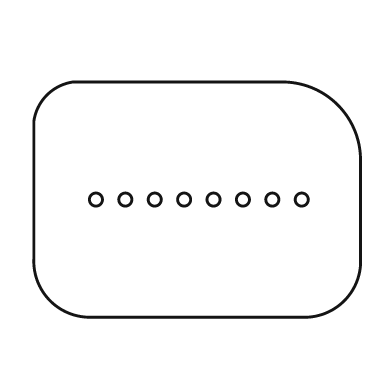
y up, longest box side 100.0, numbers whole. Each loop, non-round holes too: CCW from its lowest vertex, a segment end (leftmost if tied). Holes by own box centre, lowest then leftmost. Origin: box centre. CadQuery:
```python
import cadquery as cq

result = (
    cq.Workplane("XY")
    .moveTo(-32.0, -36.0)
    .lineTo(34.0, -36.0)
    .threePointArc((45.0, -31.0), (50.0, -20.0))
    .lineTo(50.0, 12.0)
    .threePointArc((43.0, 29.0), (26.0, 36.0))
    .lineTo(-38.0, 36.0)
    .threePointArc((-46.0, 32.0), (-50.0, 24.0))
    .lineTo(-50.0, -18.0)
    .threePointArc((-45.0, -31.0), (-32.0, -36.0))
    .close()
    .moveTo(-31.0, 0.0)
    .circle(2.0)
    .moveTo(-22.0, 0.0)
    .circle(2.0)
    .moveTo(-13.0, 0.0)
    .circle(2.0)
    .moveTo(-4.0, 0.0)
    .circle(2.0)
    .moveTo(5.0, 0.0)
    .circle(2.0)
    .moveTo(14.0, 0.0)
    .circle(2.0)
    .moveTo(23.0, 0.0)
    .circle(2.0)
    .moveTo(32.0, 0.0)
    .circle(2.0)
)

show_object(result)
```